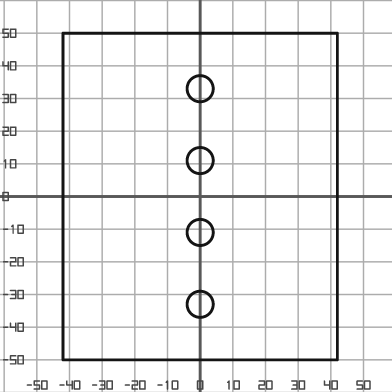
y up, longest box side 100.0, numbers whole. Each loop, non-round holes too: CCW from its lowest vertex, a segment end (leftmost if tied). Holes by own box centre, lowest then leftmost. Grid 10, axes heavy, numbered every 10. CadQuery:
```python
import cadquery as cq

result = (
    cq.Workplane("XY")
    .moveTo(-42.0, -50.0)
    .lineTo(42.0, -50.0)
    .lineTo(42.0, 50.0)
    .lineTo(-42.0, 50.0)
    .close()
    .moveTo(0.0, -33.0)
    .circle(4.0)
    .moveTo(0.0, -11.0)
    .circle(4.0)
    .moveTo(0.0, 11.0)
    .circle(4.0)
    .moveTo(0.0, 33.0)
    .circle(4.0)
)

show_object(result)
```